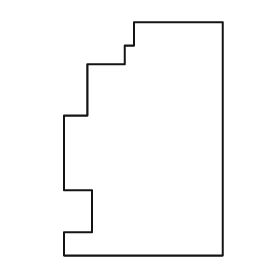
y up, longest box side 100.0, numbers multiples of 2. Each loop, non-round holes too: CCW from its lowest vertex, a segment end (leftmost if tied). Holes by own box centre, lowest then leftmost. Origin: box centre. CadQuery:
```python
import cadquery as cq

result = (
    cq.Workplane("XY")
    .moveTo(-34.0, -50.0)
    .lineTo(34.0, -50.0)
    .lineTo(34.0, 50.0)
    .lineTo(-4.0, 50.0)
    .lineTo(-4.0, 40.0)
    .lineTo(-8.0, 40.0)
    .lineTo(-8.0, 32.0)
    .lineTo(-24.0, 32.0)
    .lineTo(-24.0, 10.0)
    .lineTo(-34.0, 10.0)
    .lineTo(-34.0, -22.0)
    .lineTo(-22.0, -22.0)
    .lineTo(-22.0, -40.0)
    .lineTo(-34.0, -40.0)
    .close()
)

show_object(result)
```